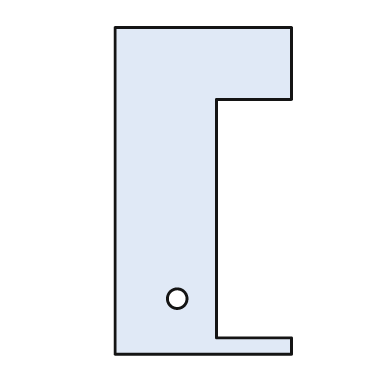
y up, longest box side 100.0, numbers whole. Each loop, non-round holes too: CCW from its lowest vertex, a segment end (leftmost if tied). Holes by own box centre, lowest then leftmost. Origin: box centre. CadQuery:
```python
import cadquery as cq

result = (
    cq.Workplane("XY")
    .moveTo(-27.0, -50.0)
    .lineTo(27.0, -50.0)
    .lineTo(27.0, -45.0)
    .lineTo(4.0, -45.0)
    .lineTo(4.0, 28.0)
    .lineTo(27.0, 28.0)
    .lineTo(27.0, 50.0)
    .lineTo(-27.0, 50.0)
    .close()
    .moveTo(-8.0, -33.0)
    .circle(3.0)
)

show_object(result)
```